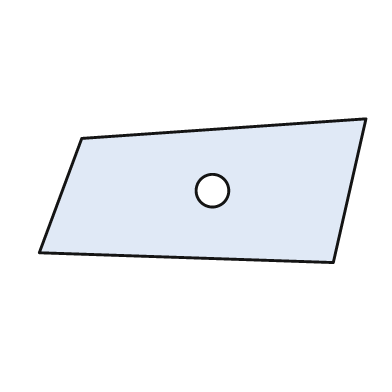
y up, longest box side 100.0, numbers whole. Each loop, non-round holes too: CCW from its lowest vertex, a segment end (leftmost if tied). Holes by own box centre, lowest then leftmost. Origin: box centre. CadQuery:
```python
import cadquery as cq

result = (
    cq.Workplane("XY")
    .moveTo(40.0, -22.0)
    .lineTo(50.0, 22.0)
    .lineTo(-37.0, 16.0)
    .lineTo(-50.0, -19.0)
    .close()
    .moveTo(3.0, 0.0)
    .circle(5.0)
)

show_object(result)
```